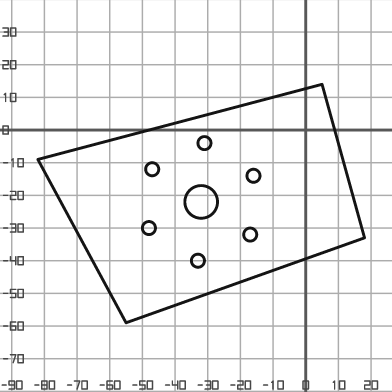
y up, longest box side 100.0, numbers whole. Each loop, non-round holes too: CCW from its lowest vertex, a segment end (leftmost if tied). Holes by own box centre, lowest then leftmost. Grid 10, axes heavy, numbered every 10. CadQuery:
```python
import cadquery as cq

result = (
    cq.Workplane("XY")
    .moveTo(-55.0, -59.0)
    .lineTo(18.0, -33.0)
    .lineTo(5.0, 14.0)
    .lineTo(-82.0, -9.0)
    .close()
    .moveTo(-33.0, -40.0)
    .circle(2.0)
    .moveTo(-17.0, -32.0)
    .circle(2.0)
    .moveTo(-48.0, -30.0)
    .circle(2.0)
    .moveTo(-32.0, -22.0)
    .circle(5.0)
    .moveTo(-16.0, -14.0)
    .circle(2.0)
    .moveTo(-47.0, -12.0)
    .circle(2.0)
    .moveTo(-31.0, -4.0)
    .circle(2.0)
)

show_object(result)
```